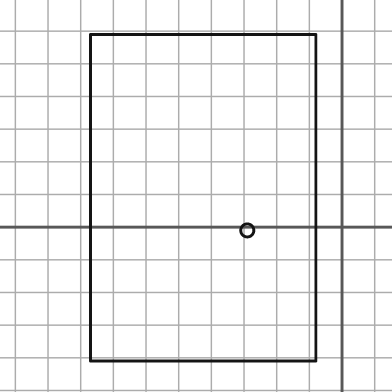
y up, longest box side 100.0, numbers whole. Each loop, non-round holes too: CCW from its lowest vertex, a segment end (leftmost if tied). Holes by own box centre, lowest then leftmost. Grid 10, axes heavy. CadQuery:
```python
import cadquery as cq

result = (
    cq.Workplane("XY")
    .moveTo(-77.0, -41.0)
    .lineTo(-8.0, -41.0)
    .lineTo(-8.0, 59.0)
    .lineTo(-77.0, 59.0)
    .close()
    .moveTo(-29.0, -1.0)
    .circle(2.0)
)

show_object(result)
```